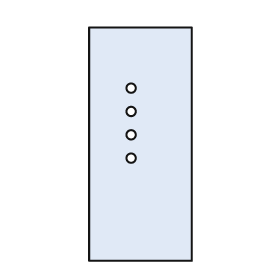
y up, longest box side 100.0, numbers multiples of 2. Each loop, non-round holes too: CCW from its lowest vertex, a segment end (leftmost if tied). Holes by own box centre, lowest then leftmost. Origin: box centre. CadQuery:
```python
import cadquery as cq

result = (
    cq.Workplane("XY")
    .moveTo(-22.0, -50.0)
    .lineTo(22.0, -50.0)
    .lineTo(22.0, 50.0)
    .lineTo(-22.0, 50.0)
    .close()
    .moveTo(-4.0, -6.0)
    .circle(2.0)
    .moveTo(-4.0, 4.0)
    .circle(2.0)
    .moveTo(-4.0, 14.0)
    .circle(2.0)
    .moveTo(-4.0, 24.0)
    .circle(2.0)
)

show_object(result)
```